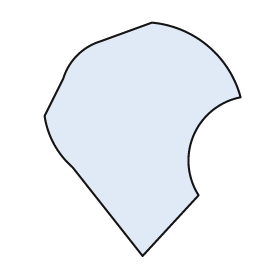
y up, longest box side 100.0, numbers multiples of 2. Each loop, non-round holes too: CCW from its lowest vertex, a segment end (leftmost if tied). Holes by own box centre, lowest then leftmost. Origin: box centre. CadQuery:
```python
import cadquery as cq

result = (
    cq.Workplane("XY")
    .moveTo(0.0, -50.0)
    .lineTo(24.0, -24.0)
    .threePointArc((22.0, 2.0), (42.0, 18.0))
    .threePointArc((28.0, 40.0), (4.0, 50.0))
    .lineTo(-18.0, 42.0)
    .threePointArc((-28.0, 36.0), (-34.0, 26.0))
    .lineTo(-42.0, 10.0)
    .threePointArc((-38.0, -2.0), (-30.0, -12.0))
    .close()
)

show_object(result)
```